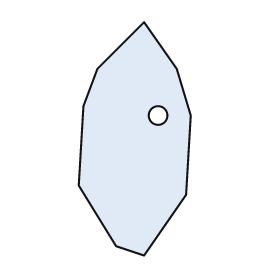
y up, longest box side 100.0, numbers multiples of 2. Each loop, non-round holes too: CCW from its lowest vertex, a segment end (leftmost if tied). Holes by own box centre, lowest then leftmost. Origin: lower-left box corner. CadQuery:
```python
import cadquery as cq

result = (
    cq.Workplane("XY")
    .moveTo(28.0, 0.0)
    .lineTo(46.0, 26.0)
    .lineTo(48.0, 60.0)
    .lineTo(42.0, 80.0)
    .lineTo(28.0, 100.0)
    .lineTo(8.0, 80.0)
    .lineTo(2.0, 64.0)
    .lineTo(0.0, 30.0)
    .lineTo(16.0, 4.0)
    .close()
    .moveTo(34.0, 60.0)
    .circle(4.0)
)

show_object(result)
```